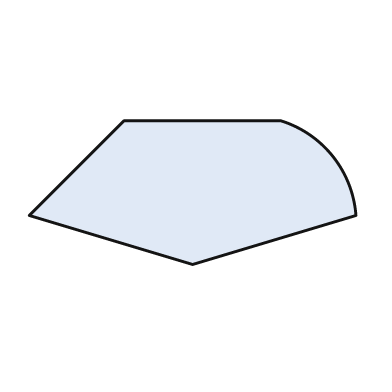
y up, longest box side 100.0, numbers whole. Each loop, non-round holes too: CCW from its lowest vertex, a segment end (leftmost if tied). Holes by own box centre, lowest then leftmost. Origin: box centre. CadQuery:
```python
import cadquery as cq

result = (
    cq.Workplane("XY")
    .moveTo(0.0, -22.0)
    .lineTo(50.0, -7.0)
    .threePointArc((43.0, 11.0), (27.0, 22.0))
    .lineTo(-21.0, 22.0)
    .lineTo(-50.0, -7.0)
    .close()
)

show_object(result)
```